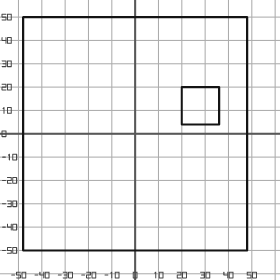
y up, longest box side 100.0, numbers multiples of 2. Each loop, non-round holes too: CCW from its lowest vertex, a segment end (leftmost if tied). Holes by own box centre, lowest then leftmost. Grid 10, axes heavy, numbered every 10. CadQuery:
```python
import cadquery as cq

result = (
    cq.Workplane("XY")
    .moveTo(-48.0, -50.0)
    .lineTo(48.0, -50.0)
    .lineTo(48.0, 50.0)
    .lineTo(-48.0, 50.0)
    .close()
    .moveTo(20.0, 4.0)
    .lineTo(36.0, 4.0)
    .lineTo(36.0, 20.0)
    .lineTo(20.0, 20.0)
    .close()
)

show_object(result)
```